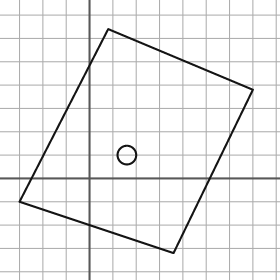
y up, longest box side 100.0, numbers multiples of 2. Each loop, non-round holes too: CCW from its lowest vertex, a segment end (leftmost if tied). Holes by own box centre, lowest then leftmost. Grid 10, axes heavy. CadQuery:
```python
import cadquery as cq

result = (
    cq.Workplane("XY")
    .moveTo(36.0, -32.0)
    .lineTo(70.0, 38.0)
    .lineTo(8.0, 64.0)
    .lineTo(-30.0, -10.0)
    .close()
    .moveTo(16.0, 10.0)
    .circle(4.0)
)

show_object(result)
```